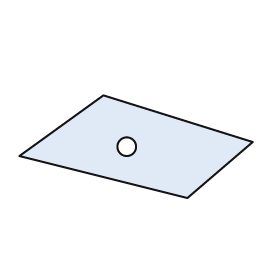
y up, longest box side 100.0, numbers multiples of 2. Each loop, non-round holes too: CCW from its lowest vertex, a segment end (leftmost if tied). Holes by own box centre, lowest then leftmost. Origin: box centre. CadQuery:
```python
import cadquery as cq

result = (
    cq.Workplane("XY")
    .moveTo(22.0, -22.0)
    .lineTo(50.0, 2.0)
    .lineTo(-14.0, 22.0)
    .lineTo(-50.0, -4.0)
    .close()
    .moveTo(-4.0, 0.0)
    .circle(4.0)
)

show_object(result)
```